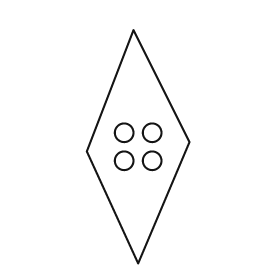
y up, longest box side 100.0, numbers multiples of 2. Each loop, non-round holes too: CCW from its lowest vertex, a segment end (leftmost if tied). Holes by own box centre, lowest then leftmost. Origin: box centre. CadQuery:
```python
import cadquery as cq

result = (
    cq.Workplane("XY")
    .moveTo(0.0, -50.0)
    .lineTo(22.0, 2.0)
    .lineTo(-2.0, 50.0)
    .lineTo(-22.0, -2.0)
    .close()
    .moveTo(-6.0, -6.0)
    .circle(4.0)
    .moveTo(6.0, -6.0)
    .circle(4.0)
    .moveTo(-6.0, 6.0)
    .circle(4.0)
    .moveTo(6.0, 6.0)
    .circle(4.0)
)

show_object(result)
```